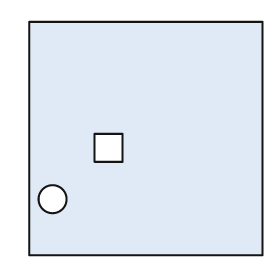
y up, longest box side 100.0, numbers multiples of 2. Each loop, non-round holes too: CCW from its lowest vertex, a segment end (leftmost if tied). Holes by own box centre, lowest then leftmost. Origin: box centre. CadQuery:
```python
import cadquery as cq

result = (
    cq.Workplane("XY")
    .moveTo(-50.0, -50.0)
    .lineTo(50.0, -50.0)
    .lineTo(50.0, 50.0)
    .lineTo(-50.0, 50.0)
    .close()
    .moveTo(-40.0, -26.0)
    .circle(6.0)
    .moveTo(-22.0, -10.0)
    .lineTo(-10.0, -10.0)
    .lineTo(-10.0, 2.0)
    .lineTo(-22.0, 2.0)
    .close()
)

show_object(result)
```